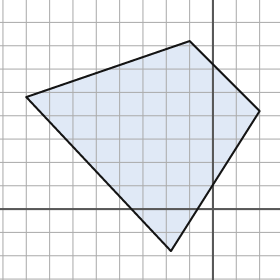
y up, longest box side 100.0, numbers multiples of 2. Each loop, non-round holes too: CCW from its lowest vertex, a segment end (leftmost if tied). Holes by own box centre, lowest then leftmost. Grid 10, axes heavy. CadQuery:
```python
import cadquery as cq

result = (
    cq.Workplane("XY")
    .moveTo(-18.0, -18.0)
    .lineTo(20.0, 42.0)
    .lineTo(-10.0, 72.0)
    .lineTo(-80.0, 48.0)
    .close()
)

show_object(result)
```